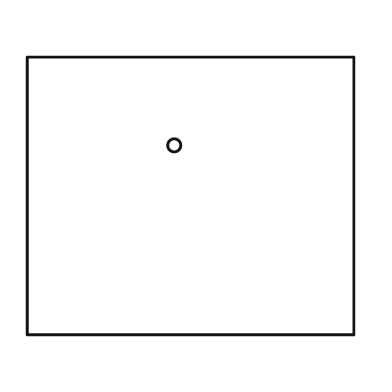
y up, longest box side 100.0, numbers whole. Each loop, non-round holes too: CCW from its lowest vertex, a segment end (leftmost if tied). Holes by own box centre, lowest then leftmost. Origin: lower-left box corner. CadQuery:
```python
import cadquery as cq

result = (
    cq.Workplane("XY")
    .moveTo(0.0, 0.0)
    .lineTo(100.0, 0.0)
    .lineTo(100.0, 85.0)
    .lineTo(0.0, 85.0)
    .close()
    .moveTo(45.0, 58.0)
    .circle(2.0)
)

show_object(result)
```